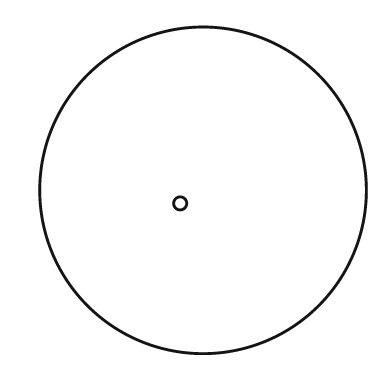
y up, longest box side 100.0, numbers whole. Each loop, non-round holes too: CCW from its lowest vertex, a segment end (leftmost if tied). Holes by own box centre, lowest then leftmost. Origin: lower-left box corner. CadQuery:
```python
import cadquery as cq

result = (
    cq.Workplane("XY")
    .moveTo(50.0, 50.0)
    .circle(50.0)
    .moveTo(43.0, 46.0)
    .circle(2.0)
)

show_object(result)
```